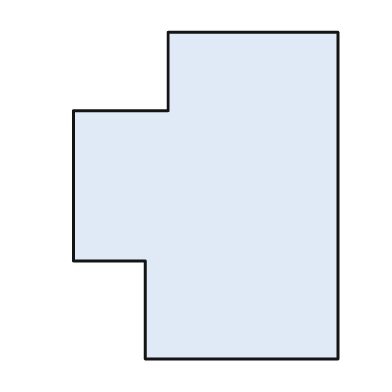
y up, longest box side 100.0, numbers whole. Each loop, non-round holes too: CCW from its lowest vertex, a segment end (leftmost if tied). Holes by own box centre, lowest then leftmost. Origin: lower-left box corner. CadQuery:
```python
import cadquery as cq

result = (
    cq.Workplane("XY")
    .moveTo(22.0, 0.0)
    .lineTo(81.0, 0.0)
    .lineTo(81.0, 100.0)
    .lineTo(29.0, 100.0)
    .lineTo(29.0, 76.0)
    .lineTo(0.0, 76.0)
    .lineTo(0.0, 30.0)
    .lineTo(22.0, 30.0)
    .close()
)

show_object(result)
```